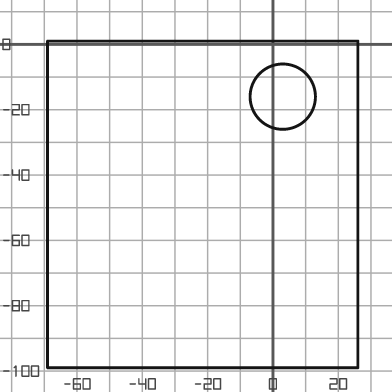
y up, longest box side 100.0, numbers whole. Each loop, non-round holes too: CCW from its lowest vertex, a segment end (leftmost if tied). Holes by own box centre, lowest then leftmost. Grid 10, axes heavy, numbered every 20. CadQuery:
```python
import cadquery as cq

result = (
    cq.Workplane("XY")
    .moveTo(-69.0, -99.0)
    .lineTo(26.0, -99.0)
    .lineTo(26.0, 1.0)
    .lineTo(-69.0, 1.0)
    .close()
    .moveTo(3.0, -16.0)
    .circle(10.0)
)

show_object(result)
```